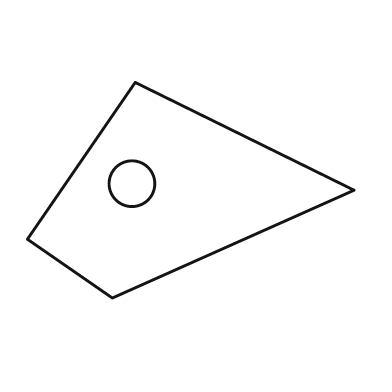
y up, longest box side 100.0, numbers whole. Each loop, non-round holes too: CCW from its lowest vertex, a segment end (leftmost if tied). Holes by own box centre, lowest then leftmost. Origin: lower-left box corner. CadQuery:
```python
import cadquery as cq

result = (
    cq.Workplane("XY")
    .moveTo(26.0, 0.0)
    .lineTo(100.0, 33.0)
    .lineTo(33.0, 66.0)
    .lineTo(0.0, 18.0)
    .close()
    .moveTo(32.0, 35.0)
    .circle(7.0)
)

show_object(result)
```